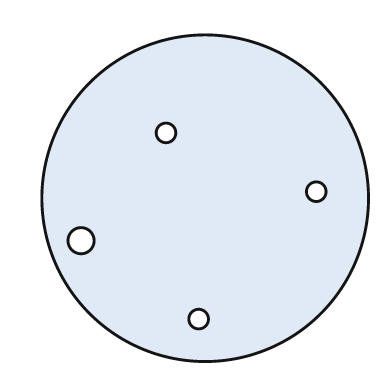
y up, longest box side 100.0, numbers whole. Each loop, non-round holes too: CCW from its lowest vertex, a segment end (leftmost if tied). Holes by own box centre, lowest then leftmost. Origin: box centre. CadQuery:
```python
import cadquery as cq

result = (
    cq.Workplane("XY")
    .moveTo(0.0, 0.0)
    .circle(50.0)
    .moveTo(-2.0, -37.0)
    .circle(3.0)
    .moveTo(-38.0, -13.0)
    .circle(4.0)
    .moveTo(34.0, 2.0)
    .circle(3.0)
    .moveTo(-12.0, 20.0)
    .circle(3.0)
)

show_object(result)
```